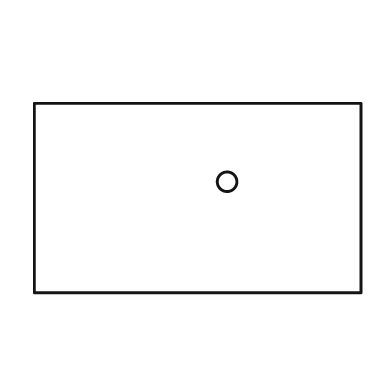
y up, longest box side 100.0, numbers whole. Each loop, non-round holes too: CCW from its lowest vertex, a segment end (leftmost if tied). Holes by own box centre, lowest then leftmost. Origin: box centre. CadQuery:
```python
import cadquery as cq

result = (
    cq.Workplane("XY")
    .moveTo(-50.0, -29.0)
    .lineTo(50.0, -29.0)
    .lineTo(50.0, 29.0)
    .lineTo(-50.0, 29.0)
    .close()
    .moveTo(9.0, 5.0)
    .circle(3.0)
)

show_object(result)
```